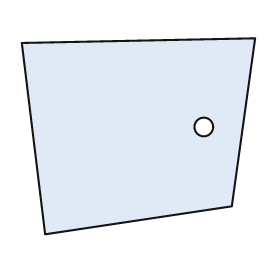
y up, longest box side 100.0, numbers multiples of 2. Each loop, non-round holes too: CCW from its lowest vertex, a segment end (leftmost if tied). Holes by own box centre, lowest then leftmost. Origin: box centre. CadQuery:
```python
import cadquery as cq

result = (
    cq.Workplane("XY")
    .moveTo(-40.0, -42.0)
    .lineTo(40.0, -30.0)
    .lineTo(50.0, 42.0)
    .lineTo(-50.0, 40.0)
    .close()
    .moveTo(28.0, 4.0)
    .circle(4.0)
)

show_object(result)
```